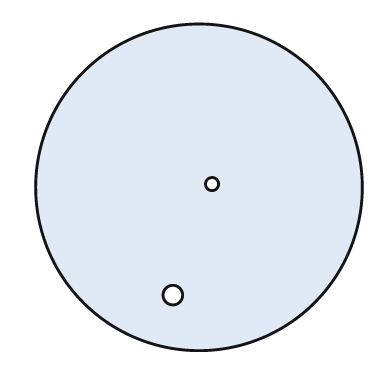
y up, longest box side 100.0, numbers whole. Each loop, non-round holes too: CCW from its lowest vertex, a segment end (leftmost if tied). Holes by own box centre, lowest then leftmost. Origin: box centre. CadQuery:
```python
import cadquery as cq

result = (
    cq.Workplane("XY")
    .moveTo(0.0, 0.0)
    .circle(50.0)
    .moveTo(-8.0, -33.0)
    .circle(3.0)
    .moveTo(4.0, 1.0)
    .circle(2.0)
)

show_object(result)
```